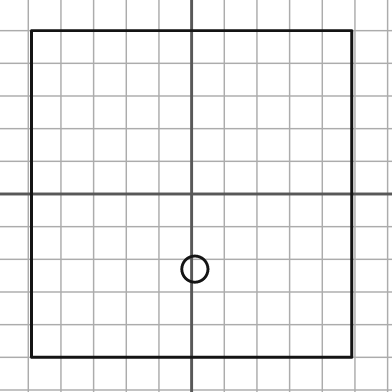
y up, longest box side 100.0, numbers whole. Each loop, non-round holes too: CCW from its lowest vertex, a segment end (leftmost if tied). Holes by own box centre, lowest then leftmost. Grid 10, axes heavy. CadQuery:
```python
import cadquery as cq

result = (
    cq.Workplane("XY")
    .moveTo(-49.0, -50.0)
    .lineTo(49.0, -50.0)
    .lineTo(49.0, 50.0)
    .lineTo(-49.0, 50.0)
    .close()
    .moveTo(1.0, -23.0)
    .circle(4.0)
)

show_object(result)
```